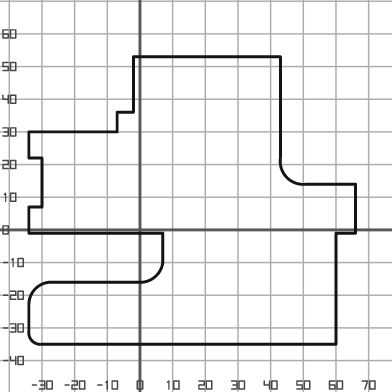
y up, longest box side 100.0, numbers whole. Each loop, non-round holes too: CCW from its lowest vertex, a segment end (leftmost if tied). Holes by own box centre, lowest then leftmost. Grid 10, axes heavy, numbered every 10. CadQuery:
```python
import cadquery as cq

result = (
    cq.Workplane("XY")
    .moveTo(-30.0, -35.0)
    .lineTo(60.0, -35.0)
    .lineTo(60.0, -1.0)
    .lineTo(66.0, -1.0)
    .lineTo(66.0, 14.0)
    .lineTo(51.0, 14.0)
    .threePointArc((45.0, 16.0), (43.0, 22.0))
    .lineTo(43.0, 53.0)
    .lineTo(-2.0, 53.0)
    .lineTo(-2.0, 36.0)
    .lineTo(-7.0, 36.0)
    .lineTo(-7.0, 30.0)
    .lineTo(-34.0, 30.0)
    .lineTo(-34.0, 22.0)
    .lineTo(-30.0, 22.0)
    .lineTo(-30.0, 7.0)
    .lineTo(-34.0, 7.0)
    .lineTo(-34.0, -1.0)
    .lineTo(7.0, -1.0)
    .lineTo(7.0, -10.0)
    .threePointArc((5.0, -14.0), (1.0, -16.0))
    .lineTo(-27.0, -16.0)
    .threePointArc((-32.0, -18.0), (-34.0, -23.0))
    .lineTo(-34.0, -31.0)
    .threePointArc((-33.0, -34.0), (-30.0, -35.0))
    .close()
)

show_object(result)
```